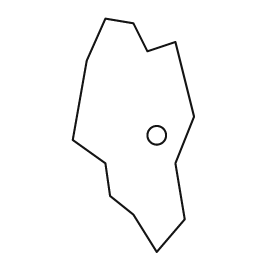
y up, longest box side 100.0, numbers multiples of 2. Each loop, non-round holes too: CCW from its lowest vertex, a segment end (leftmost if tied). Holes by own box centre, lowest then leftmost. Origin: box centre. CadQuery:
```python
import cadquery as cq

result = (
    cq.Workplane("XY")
    .moveTo(10.0, -50.0)
    .lineTo(22.0, -36.0)
    .lineTo(18.0, -12.0)
    .lineTo(26.0, 8.0)
    .lineTo(18.0, 40.0)
    .lineTo(6.0, 36.0)
    .lineTo(0.0, 48.0)
    .lineTo(-12.0, 50.0)
    .lineTo(-20.0, 32.0)
    .lineTo(-26.0, -2.0)
    .lineTo(-12.0, -12.0)
    .lineTo(-10.0, -26.0)
    .lineTo(0.0, -34.0)
    .close()
    .moveTo(10.0, 0.0)
    .circle(4.0)
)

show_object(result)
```